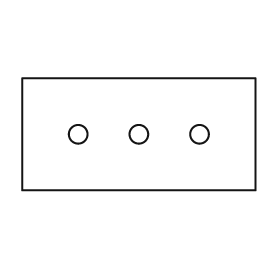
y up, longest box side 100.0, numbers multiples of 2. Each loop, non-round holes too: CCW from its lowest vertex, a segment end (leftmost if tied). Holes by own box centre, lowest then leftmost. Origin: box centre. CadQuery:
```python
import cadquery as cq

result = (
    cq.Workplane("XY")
    .moveTo(-50.0, -24.0)
    .lineTo(50.0, -24.0)
    .lineTo(50.0, 24.0)
    .lineTo(-50.0, 24.0)
    .close()
    .moveTo(-26.0, 0.0)
    .circle(4.0)
    .moveTo(0.0, 0.0)
    .circle(4.0)
    .moveTo(26.0, 0.0)
    .circle(4.0)
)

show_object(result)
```